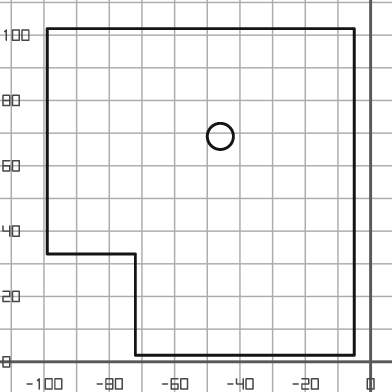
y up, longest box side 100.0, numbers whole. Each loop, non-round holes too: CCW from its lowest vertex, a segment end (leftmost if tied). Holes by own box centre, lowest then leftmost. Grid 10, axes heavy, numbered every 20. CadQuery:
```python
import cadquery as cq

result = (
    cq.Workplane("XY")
    .moveTo(-72.0, 2.0)
    .lineTo(-5.0, 2.0)
    .lineTo(-5.0, 102.0)
    .lineTo(-99.0, 102.0)
    .lineTo(-99.0, 33.0)
    .lineTo(-72.0, 33.0)
    .close()
    .moveTo(-46.0, 69.0)
    .circle(4.0)
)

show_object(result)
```